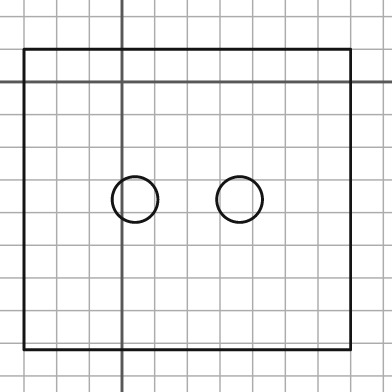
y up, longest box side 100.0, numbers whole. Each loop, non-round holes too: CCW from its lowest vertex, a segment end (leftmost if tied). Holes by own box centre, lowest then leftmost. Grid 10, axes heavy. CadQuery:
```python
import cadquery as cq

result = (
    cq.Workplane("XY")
    .moveTo(-30.0, -82.0)
    .lineTo(70.0, -82.0)
    .lineTo(70.0, 10.0)
    .lineTo(-30.0, 10.0)
    .close()
    .moveTo(4.0, -36.0)
    .circle(7.0)
    .moveTo(36.0, -36.0)
    .circle(7.0)
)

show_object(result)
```